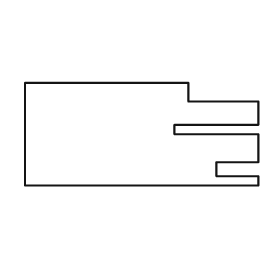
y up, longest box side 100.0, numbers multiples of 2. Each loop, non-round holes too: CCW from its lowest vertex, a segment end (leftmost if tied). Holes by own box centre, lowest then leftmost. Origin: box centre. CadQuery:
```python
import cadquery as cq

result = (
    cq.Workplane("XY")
    .moveTo(-50.0, -22.0)
    .lineTo(50.0, -22.0)
    .lineTo(50.0, -18.0)
    .lineTo(32.0, -18.0)
    .lineTo(32.0, -12.0)
    .lineTo(50.0, -12.0)
    .lineTo(50.0, 0.0)
    .lineTo(14.0, 0.0)
    .lineTo(14.0, 4.0)
    .lineTo(50.0, 4.0)
    .lineTo(50.0, 14.0)
    .lineTo(20.0, 14.0)
    .lineTo(20.0, 22.0)
    .lineTo(-50.0, 22.0)
    .close()
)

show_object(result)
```